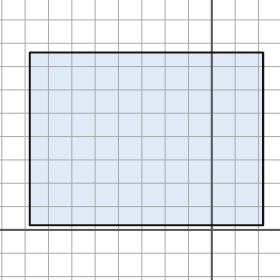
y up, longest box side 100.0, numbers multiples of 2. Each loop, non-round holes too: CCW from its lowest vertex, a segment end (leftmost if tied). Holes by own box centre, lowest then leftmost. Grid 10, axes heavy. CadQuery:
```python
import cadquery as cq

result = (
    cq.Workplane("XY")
    .moveTo(-78.0, 2.0)
    .lineTo(22.0, 2.0)
    .lineTo(22.0, 76.0)
    .lineTo(-78.0, 76.0)
    .close()
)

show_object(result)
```